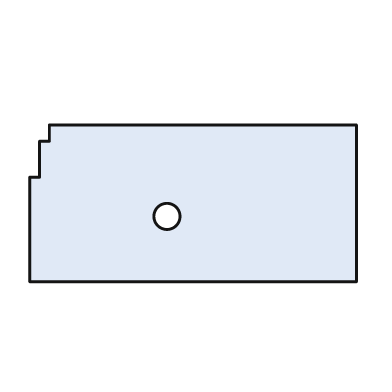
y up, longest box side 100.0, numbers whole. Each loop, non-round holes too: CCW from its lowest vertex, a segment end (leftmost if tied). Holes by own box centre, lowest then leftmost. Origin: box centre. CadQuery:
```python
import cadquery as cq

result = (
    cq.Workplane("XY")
    .moveTo(-50.0, -24.0)
    .lineTo(50.0, -24.0)
    .lineTo(50.0, 24.0)
    .lineTo(-44.0, 24.0)
    .lineTo(-44.0, 19.0)
    .lineTo(-47.0, 19.0)
    .lineTo(-47.0, 8.0)
    .lineTo(-50.0, 8.0)
    .close()
    .moveTo(-8.0, -4.0)
    .circle(4.0)
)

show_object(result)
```